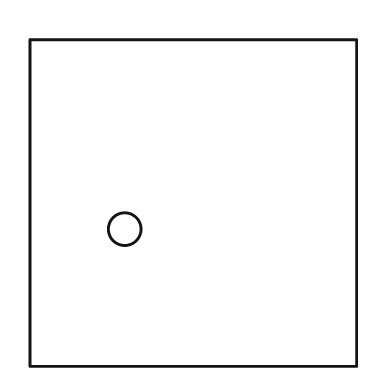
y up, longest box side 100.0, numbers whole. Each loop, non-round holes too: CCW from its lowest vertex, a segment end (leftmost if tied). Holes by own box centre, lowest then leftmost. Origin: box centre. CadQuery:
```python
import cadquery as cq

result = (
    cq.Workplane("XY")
    .moveTo(-50.0, -50.0)
    .lineTo(50.0, -50.0)
    .lineTo(50.0, 50.0)
    .lineTo(-50.0, 50.0)
    .close()
    .moveTo(-21.0, -8.0)
    .circle(5.0)
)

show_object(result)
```